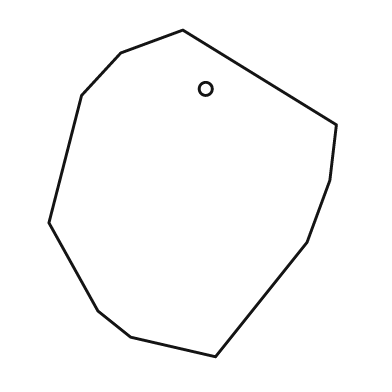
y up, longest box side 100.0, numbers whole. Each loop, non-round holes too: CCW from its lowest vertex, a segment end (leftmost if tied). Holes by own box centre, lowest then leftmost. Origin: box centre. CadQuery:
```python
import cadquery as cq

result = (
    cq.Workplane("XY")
    .moveTo(7.0, -50.0)
    .lineTo(35.0, -15.0)
    .lineTo(42.0, 4.0)
    .lineTo(44.0, 21.0)
    .lineTo(-3.0, 50.0)
    .lineTo(-22.0, 43.0)
    .lineTo(-34.0, 30.0)
    .lineTo(-44.0, -9.0)
    .lineTo(-29.0, -36.0)
    .lineTo(-19.0, -44.0)
    .close()
    .moveTo(4.0, 32.0)
    .circle(2.0)
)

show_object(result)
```